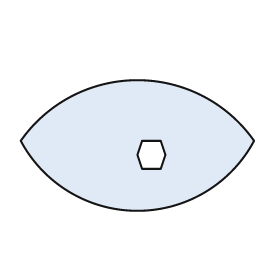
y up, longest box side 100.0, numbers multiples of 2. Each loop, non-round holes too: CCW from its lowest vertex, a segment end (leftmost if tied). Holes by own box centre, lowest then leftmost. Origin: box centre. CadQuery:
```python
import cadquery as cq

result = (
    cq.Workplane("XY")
    .moveTo(-50.0, 2.0)
    .threePointArc((0.0, -28.0), (50.0, 2.0))
    .threePointArc((0.0, 28.0), (-50.0, 2.0))
    .close()
    .moveTo(2.0, -10.0)
    .lineTo(10.0, -10.0)
    .lineTo(12.0, -4.0)
    .lineTo(10.0, 2.0)
    .lineTo(2.0, 2.0)
    .lineTo(0.0, -4.0)
    .close()
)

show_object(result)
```